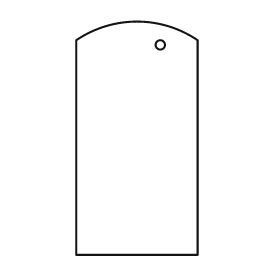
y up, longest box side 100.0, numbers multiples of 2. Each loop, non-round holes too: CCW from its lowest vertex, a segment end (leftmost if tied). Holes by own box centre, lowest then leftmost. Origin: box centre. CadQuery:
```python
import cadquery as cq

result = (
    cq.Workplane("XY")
    .moveTo(-26.0, -50.0)
    .lineTo(26.0, -50.0)
    .lineTo(26.0, 42.0)
    .threePointArc((0.0, 50.0), (-26.0, 42.0))
    .close()
    .moveTo(10.0, 40.0)
    .circle(2.0)
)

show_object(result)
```